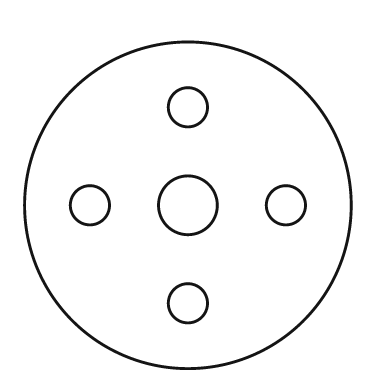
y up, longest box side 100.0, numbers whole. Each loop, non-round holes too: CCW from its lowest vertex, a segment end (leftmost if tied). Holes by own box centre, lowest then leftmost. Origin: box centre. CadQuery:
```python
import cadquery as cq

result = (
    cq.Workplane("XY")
    .moveTo(0.0, 0.0)
    .circle(50.0)
    .moveTo(0.0, -30.0)
    .circle(6.0)
    .moveTo(-30.0, 0.0)
    .circle(6.0)
    .moveTo(0.0, 0.0)
    .circle(9.0)
    .moveTo(30.0, 0.0)
    .circle(6.0)
    .moveTo(0.0, 30.0)
    .circle(6.0)
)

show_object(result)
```